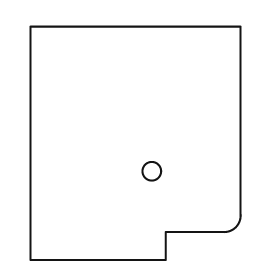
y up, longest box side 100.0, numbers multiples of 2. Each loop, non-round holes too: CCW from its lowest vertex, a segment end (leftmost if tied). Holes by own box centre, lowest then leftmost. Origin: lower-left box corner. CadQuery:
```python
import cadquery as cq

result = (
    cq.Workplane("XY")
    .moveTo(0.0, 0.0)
    .lineTo(58.0, 0.0)
    .lineTo(58.0, 12.0)
    .lineTo(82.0, 12.0)
    .threePointArc((88.0, 14.0), (90.0, 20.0))
    .lineTo(90.0, 100.0)
    .lineTo(0.0, 100.0)
    .close()
    .moveTo(52.0, 38.0)
    .circle(4.0)
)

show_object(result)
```